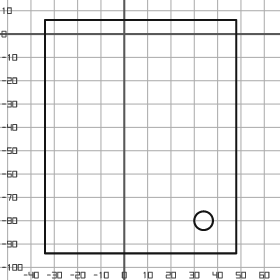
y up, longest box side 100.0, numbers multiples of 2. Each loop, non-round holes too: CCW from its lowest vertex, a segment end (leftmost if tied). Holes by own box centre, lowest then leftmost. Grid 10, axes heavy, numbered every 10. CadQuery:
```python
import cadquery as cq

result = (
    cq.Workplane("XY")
    .moveTo(-34.0, -94.0)
    .lineTo(48.0, -94.0)
    .lineTo(48.0, 6.0)
    .lineTo(-34.0, 6.0)
    .close()
    .moveTo(34.0, -80.0)
    .circle(4.0)
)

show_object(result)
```